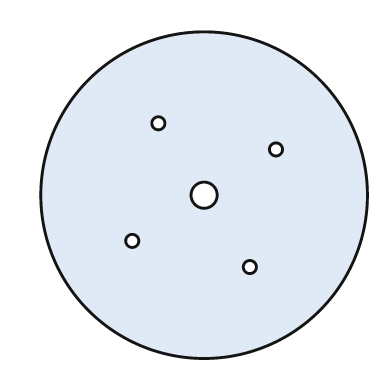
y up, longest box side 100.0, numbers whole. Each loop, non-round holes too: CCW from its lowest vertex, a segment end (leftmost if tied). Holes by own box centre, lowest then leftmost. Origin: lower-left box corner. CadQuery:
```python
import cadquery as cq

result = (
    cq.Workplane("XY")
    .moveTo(50.0, 50.0)
    .circle(50.0)
    .moveTo(64.0, 28.0)
    .circle(2.0)
    .moveTo(28.0, 36.0)
    .circle(2.0)
    .moveTo(50.0, 50.0)
    .circle(4.0)
    .moveTo(72.0, 64.0)
    .circle(2.0)
    .moveTo(36.0, 72.0)
    .circle(2.0)
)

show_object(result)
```